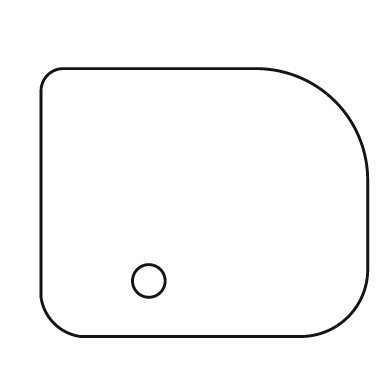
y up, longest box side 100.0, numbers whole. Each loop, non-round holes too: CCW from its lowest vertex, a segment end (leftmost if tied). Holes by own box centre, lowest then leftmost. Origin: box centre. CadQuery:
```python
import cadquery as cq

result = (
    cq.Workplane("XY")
    .moveTo(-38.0, -41.0)
    .lineTo(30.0, -41.0)
    .threePointArc((44.0, -35.0), (50.0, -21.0))
    .lineTo(50.0, 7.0)
    .threePointArc((40.0, 31.0), (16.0, 41.0))
    .lineTo(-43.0, 41.0)
    .threePointArc((-48.0, 39.0), (-50.0, 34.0))
    .lineTo(-50.0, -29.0)
    .threePointArc((-46.0, -37.0), (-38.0, -41.0))
    .close()
    .moveTo(-17.0, -24.0)
    .circle(5.0)
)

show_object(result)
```